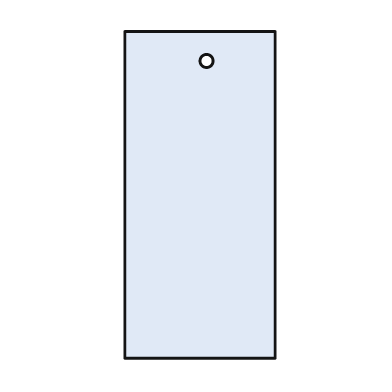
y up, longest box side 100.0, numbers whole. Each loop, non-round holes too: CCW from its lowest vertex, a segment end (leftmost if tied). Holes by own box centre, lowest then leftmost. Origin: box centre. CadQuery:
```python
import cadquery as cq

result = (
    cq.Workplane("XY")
    .moveTo(-23.0, -50.0)
    .lineTo(23.0, -50.0)
    .lineTo(23.0, 50.0)
    .lineTo(-23.0, 50.0)
    .close()
    .moveTo(2.0, 41.0)
    .circle(2.0)
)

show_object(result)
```